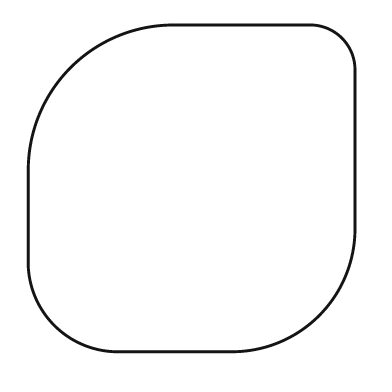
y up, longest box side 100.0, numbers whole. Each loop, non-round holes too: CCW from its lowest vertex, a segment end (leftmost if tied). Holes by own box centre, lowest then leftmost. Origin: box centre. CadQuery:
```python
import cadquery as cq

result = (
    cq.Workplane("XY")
    .moveTo(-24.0, -50.0)
    .lineTo(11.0, -50.0)
    .threePointArc((39.0, -39.0), (50.0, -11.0))
    .lineTo(50.0, 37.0)
    .threePointArc((46.0, 46.0), (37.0, 50.0))
    .lineTo(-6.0, 50.0)
    .threePointArc((-37.0, 37.0), (-50.0, 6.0))
    .lineTo(-50.0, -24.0)
    .threePointArc((-42.0, -42.0), (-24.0, -50.0))
    .close()
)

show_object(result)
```